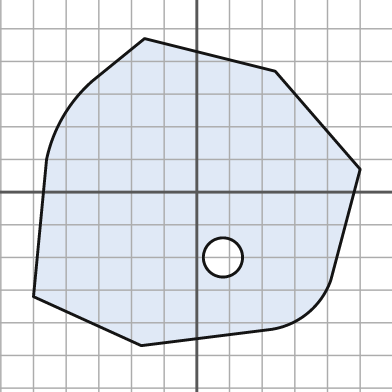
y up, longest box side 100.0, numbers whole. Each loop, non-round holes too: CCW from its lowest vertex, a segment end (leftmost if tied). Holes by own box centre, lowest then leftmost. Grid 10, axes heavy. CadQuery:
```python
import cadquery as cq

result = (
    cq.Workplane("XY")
    .moveTo(-17.0, -47.0)
    .lineTo(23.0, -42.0)
    .threePointArc((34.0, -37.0), (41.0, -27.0))
    .lineTo(50.0, 7.0)
    .lineTo(24.0, 37.0)
    .lineTo(-16.0, 47.0)
    .lineTo(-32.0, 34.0)
    .threePointArc((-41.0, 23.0), (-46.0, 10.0))
    .lineTo(-50.0, -32.0)
    .close()
    .moveTo(8.0, -20.0)
    .circle(6.0)
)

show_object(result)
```